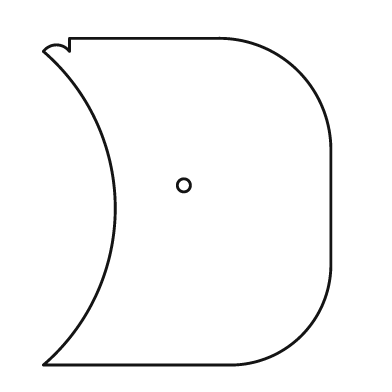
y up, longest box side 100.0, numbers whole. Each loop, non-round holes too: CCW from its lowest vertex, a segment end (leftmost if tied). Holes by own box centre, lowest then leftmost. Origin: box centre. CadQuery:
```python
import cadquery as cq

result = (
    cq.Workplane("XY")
    .moveTo(-44.0, -50.0)
    .lineTo(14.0, -50.0)
    .threePointArc((35.0, -41.0), (44.0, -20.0))
    .lineTo(44.0, 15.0)
    .threePointArc((34.0, 40.0), (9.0, 50.0))
    .lineTo(-36.0, 50.0)
    .lineTo(-36.0, 46.0)
    .threePointArc((-40.0, 48.0), (-44.0, 46.0))
    .threePointArc((-22.0, -2.0), (-44.0, -50.0))
    .close()
    .moveTo(-1.0, 5.0)
    .circle(2.0)
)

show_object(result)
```